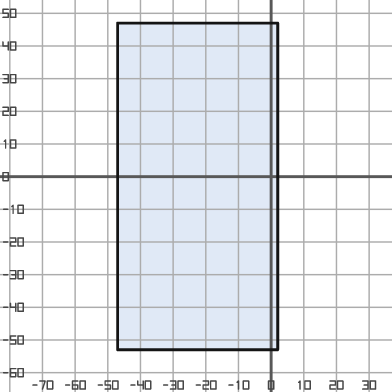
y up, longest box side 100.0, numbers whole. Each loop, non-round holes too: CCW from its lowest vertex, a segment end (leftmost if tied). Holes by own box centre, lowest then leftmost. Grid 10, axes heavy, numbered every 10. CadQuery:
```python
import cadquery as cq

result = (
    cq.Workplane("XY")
    .moveTo(-47.0, -53.0)
    .lineTo(2.0, -53.0)
    .lineTo(2.0, 47.0)
    .lineTo(-47.0, 47.0)
    .close()
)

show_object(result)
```